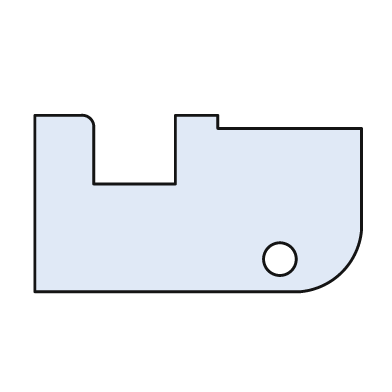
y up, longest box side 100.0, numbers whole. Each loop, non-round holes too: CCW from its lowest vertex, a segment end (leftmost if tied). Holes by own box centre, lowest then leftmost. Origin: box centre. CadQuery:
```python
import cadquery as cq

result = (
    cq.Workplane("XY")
    .moveTo(-50.0, -27.0)
    .lineTo(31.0, -27.0)
    .threePointArc((44.0, -21.0), (50.0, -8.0))
    .lineTo(50.0, 23.0)
    .lineTo(6.0, 23.0)
    .lineTo(6.0, 27.0)
    .lineTo(-7.0, 27.0)
    .lineTo(-7.0, 6.0)
    .lineTo(-32.0, 6.0)
    .lineTo(-32.0, 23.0)
    .threePointArc((-33.0, 26.0), (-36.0, 27.0))
    .lineTo(-50.0, 27.0)
    .close()
    .moveTo(25.0, -17.0)
    .circle(5.0)
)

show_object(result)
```